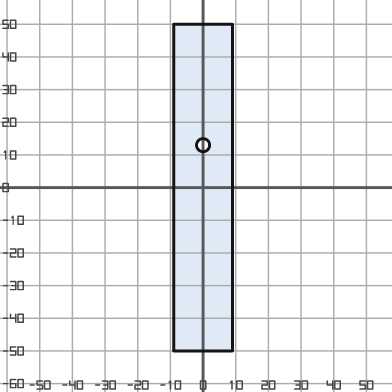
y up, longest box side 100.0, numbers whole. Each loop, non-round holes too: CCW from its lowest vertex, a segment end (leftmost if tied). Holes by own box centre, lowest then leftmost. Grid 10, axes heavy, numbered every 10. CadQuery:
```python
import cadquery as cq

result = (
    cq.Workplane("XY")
    .moveTo(-9.0, -50.0)
    .lineTo(9.0, -50.0)
    .lineTo(9.0, 50.0)
    .lineTo(-9.0, 50.0)
    .close()
    .moveTo(0.0, 13.0)
    .circle(2.0)
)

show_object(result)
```